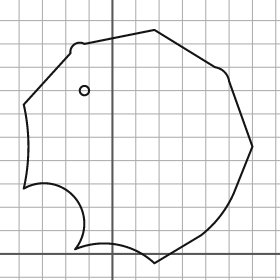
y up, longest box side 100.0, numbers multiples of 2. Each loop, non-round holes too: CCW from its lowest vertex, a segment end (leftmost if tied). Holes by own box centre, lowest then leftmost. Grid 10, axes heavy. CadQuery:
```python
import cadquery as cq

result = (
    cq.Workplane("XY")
    .moveTo(18.0, -4.0)
    .lineTo(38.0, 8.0)
    .threePointArc((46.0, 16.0), (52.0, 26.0))
    .lineTo(60.0, 46.0)
    .lineTo(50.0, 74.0)
    .threePointArc((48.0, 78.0), (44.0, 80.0))
    .lineTo(18.0, 96.0)
    .lineTo(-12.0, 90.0)
    .threePointArc((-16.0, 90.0), (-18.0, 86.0))
    .lineTo(-38.0, 64.0)
    .threePointArc((-36.0, 46.0), (-38.0, 28.0))
    .threePointArc((-16.0, 24.0), (-16.0, 2.0))
    .threePointArc((2.0, 4.0), (18.0, -4.0))
    .close()
    .moveTo(-12.0, 70.0)
    .circle(2.0)
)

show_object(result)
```